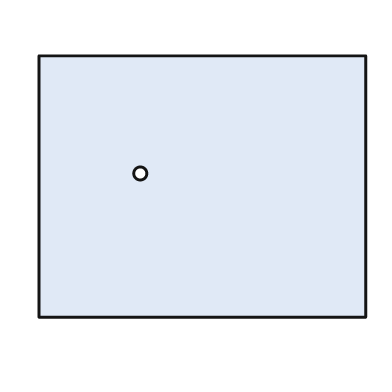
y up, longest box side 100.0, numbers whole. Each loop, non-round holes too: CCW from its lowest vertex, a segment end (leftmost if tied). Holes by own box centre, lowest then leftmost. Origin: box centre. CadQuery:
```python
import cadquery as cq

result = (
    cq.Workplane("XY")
    .moveTo(-50.0, -40.0)
    .lineTo(50.0, -40.0)
    .lineTo(50.0, 40.0)
    .lineTo(-50.0, 40.0)
    .close()
    .moveTo(-19.0, 4.0)
    .circle(2.0)
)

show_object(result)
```